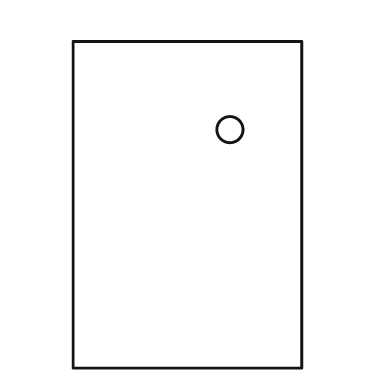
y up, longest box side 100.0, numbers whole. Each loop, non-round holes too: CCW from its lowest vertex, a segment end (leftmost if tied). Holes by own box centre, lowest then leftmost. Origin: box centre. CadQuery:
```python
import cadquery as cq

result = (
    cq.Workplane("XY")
    .moveTo(-35.0, -50.0)
    .lineTo(35.0, -50.0)
    .lineTo(35.0, 50.0)
    .lineTo(-35.0, 50.0)
    .close()
    .moveTo(13.0, 23.0)
    .circle(4.0)
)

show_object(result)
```